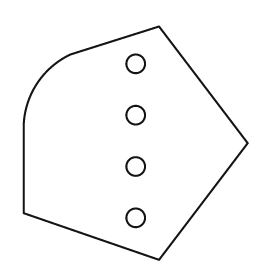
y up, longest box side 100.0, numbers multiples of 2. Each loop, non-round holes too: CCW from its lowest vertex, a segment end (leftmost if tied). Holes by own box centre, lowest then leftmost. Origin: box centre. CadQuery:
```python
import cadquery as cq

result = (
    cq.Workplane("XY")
    .moveTo(10.0, -50.0)
    .lineTo(48.0, 0.0)
    .lineTo(10.0, 50.0)
    .lineTo(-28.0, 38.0)
    .threePointArc((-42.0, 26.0), (-48.0, 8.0))
    .lineTo(-48.0, -30.0)
    .close()
    .moveTo(0.0, -32.0)
    .circle(4.0)
    .moveTo(0.0, -10.0)
    .circle(4.0)
    .moveTo(0.0, 12.0)
    .circle(4.0)
    .moveTo(0.0, 34.0)
    .circle(4.0)
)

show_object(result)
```